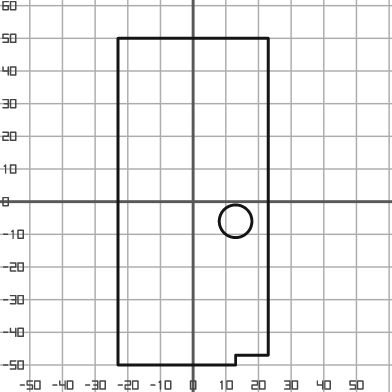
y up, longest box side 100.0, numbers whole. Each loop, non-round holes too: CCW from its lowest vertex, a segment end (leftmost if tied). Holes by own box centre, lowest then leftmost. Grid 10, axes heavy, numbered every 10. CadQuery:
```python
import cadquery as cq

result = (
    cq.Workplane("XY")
    .moveTo(-23.0, -50.0)
    .lineTo(13.0, -50.0)
    .lineTo(13.0, -47.0)
    .lineTo(23.0, -47.0)
    .lineTo(23.0, 50.0)
    .lineTo(-23.0, 50.0)
    .close()
    .moveTo(13.0, -6.0)
    .circle(5.0)
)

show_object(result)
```